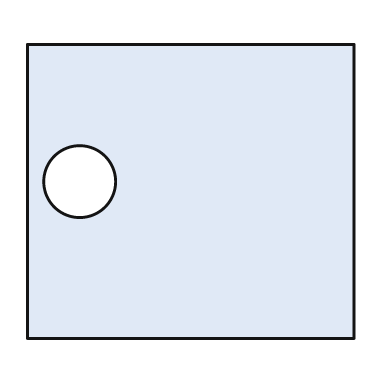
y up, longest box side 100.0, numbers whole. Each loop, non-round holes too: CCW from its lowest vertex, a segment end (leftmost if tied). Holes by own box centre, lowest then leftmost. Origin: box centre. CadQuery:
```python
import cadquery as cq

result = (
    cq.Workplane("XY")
    .moveTo(-50.0, -45.0)
    .lineTo(50.0, -45.0)
    .lineTo(50.0, 45.0)
    .lineTo(-50.0, 45.0)
    .close()
    .moveTo(-34.0, 3.0)
    .circle(11.0)
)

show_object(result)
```